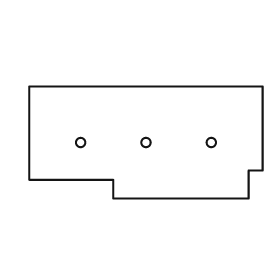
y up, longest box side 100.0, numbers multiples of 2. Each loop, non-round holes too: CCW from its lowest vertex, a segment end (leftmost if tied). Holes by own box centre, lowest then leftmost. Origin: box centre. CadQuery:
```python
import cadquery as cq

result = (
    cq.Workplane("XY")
    .moveTo(-14.0, -24.0)
    .lineTo(44.0, -24.0)
    .lineTo(44.0, -12.0)
    .lineTo(50.0, -12.0)
    .lineTo(50.0, 24.0)
    .lineTo(-50.0, 24.0)
    .lineTo(-50.0, -16.0)
    .lineTo(-14.0, -16.0)
    .close()
    .moveTo(-28.0, 0.0)
    .circle(2.0)
    .moveTo(0.0, 0.0)
    .circle(2.0)
    .moveTo(28.0, 0.0)
    .circle(2.0)
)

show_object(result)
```